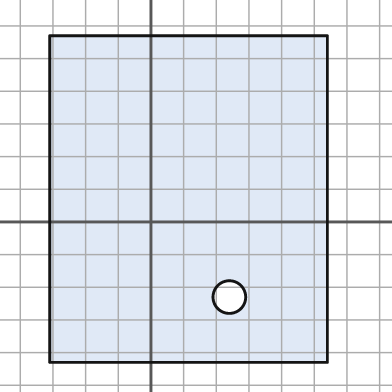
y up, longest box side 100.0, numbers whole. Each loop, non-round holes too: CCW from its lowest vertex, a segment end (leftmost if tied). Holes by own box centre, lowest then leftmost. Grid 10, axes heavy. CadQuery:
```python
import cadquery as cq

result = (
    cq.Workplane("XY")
    .moveTo(-31.0, -43.0)
    .lineTo(54.0, -43.0)
    .lineTo(54.0, 57.0)
    .lineTo(-31.0, 57.0)
    .close()
    .moveTo(24.0, -23.0)
    .circle(5.0)
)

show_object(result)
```